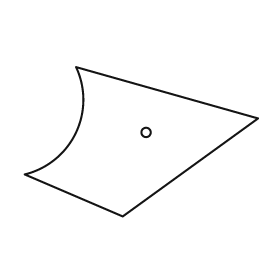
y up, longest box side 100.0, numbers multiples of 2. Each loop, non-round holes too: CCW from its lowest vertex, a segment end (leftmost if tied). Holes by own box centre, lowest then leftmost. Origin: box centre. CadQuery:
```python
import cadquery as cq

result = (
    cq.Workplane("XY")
    .moveTo(-8.0, -32.0)
    .lineTo(50.0, 10.0)
    .lineTo(-28.0, 32.0)
    .threePointArc((-28.0, 4.0), (-50.0, -14.0))
    .close()
    .moveTo(2.0, 4.0)
    .circle(2.0)
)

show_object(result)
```